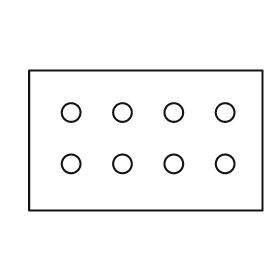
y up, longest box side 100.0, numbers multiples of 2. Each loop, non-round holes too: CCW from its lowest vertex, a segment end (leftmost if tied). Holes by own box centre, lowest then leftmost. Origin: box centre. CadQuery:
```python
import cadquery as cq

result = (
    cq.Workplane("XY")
    .moveTo(-50.0, -30.0)
    .lineTo(50.0, -30.0)
    .lineTo(50.0, 30.0)
    .lineTo(-50.0, 30.0)
    .close()
    .moveTo(-32.0, -10.0)
    .circle(4.0)
    .moveTo(-10.0, -10.0)
    .circle(4.0)
    .moveTo(12.0, -10.0)
    .circle(4.0)
    .moveTo(34.0, -10.0)
    .circle(4.0)
    .moveTo(-32.0, 12.0)
    .circle(4.0)
    .moveTo(-10.0, 12.0)
    .circle(4.0)
    .moveTo(12.0, 12.0)
    .circle(4.0)
    .moveTo(34.0, 12.0)
    .circle(4.0)
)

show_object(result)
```